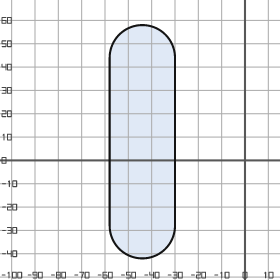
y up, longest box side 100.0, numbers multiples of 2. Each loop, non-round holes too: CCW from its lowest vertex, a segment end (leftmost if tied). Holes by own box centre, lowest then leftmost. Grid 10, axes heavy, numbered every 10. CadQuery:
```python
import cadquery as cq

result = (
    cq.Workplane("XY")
    .moveTo(-58.0, -28.0)
    .threePointArc((-44.0, -42.0), (-30.0, -28.0))
    .lineTo(-30.0, 44.0)
    .threePointArc((-44.0, 58.0), (-58.0, 44.0))
    .close()
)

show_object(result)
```